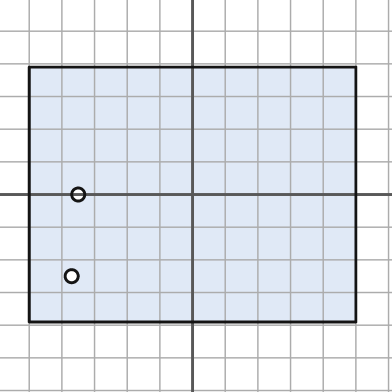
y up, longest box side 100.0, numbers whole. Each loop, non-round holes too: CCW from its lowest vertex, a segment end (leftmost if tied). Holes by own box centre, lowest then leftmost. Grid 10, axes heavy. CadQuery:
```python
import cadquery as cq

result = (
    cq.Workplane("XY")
    .moveTo(-50.0, -39.0)
    .lineTo(50.0, -39.0)
    .lineTo(50.0, 39.0)
    .lineTo(-50.0, 39.0)
    .close()
    .moveTo(-37.0, -25.0)
    .circle(2.0)
    .moveTo(-35.0, 0.0)
    .circle(2.0)
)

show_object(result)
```